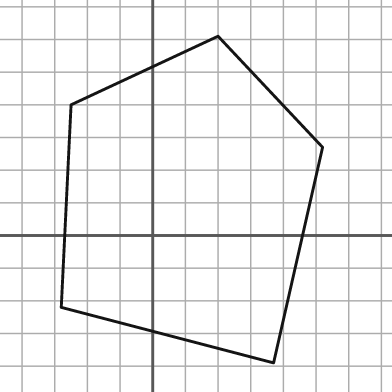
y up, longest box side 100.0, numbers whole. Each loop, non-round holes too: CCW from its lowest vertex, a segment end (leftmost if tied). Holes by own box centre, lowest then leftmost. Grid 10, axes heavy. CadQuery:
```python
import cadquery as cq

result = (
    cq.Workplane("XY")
    .moveTo(37.0, -39.0)
    .lineTo(52.0, 27.0)
    .lineTo(20.0, 61.0)
    .lineTo(-25.0, 40.0)
    .lineTo(-28.0, -22.0)
    .close()
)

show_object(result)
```